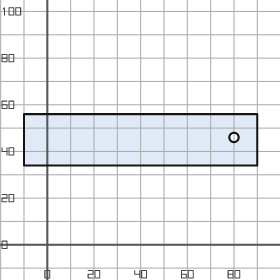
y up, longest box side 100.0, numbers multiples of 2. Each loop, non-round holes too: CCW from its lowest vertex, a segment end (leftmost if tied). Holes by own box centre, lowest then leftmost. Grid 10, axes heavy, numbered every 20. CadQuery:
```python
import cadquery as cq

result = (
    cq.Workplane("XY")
    .moveTo(-10.0, 34.0)
    .lineTo(90.0, 34.0)
    .lineTo(90.0, 56.0)
    .lineTo(-10.0, 56.0)
    .close()
    .moveTo(80.0, 46.0)
    .circle(2.0)
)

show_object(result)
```